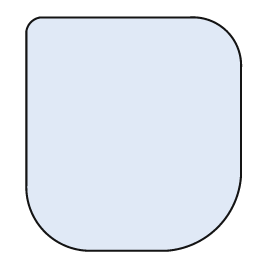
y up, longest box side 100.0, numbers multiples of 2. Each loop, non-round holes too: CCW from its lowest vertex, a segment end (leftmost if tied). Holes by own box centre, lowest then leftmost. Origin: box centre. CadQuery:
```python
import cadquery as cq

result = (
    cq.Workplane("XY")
    .moveTo(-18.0, -50.0)
    .lineTo(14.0, -50.0)
    .threePointArc((36.0, -40.0), (46.0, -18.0))
    .lineTo(46.0, 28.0)
    .threePointArc((40.0, 44.0), (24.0, 50.0))
    .lineTo(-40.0, 50.0)
    .threePointArc((-44.0, 48.0), (-46.0, 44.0))
    .lineTo(-46.0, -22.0)
    .threePointArc((-38.0, -42.0), (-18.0, -50.0))
    .close()
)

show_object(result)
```